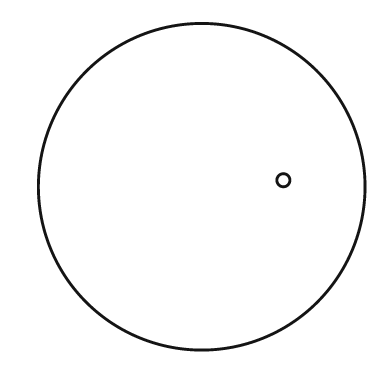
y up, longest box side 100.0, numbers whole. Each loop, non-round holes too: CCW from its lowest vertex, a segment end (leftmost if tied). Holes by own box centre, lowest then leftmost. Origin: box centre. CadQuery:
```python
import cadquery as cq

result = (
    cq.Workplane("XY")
    .moveTo(0.0, 0.0)
    .circle(50.0)
    .moveTo(25.0, 2.0)
    .circle(2.0)
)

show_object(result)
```